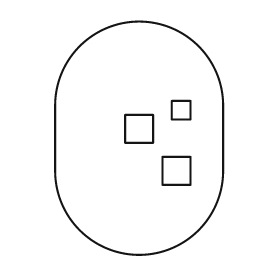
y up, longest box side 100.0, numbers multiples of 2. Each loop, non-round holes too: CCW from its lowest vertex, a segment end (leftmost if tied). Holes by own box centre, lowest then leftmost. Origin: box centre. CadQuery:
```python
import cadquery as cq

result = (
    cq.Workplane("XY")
    .moveTo(-36.0, -14.0)
    .threePointArc((0.0, -50.0), (36.0, -14.0))
    .lineTo(36.0, 14.0)
    .threePointArc((0.0, 50.0), (-36.0, 14.0))
    .close()
    .moveTo(10.0, -20.0)
    .lineTo(22.0, -20.0)
    .lineTo(22.0, -8.0)
    .lineTo(10.0, -8.0)
    .close()
    .moveTo(-6.0, -2.0)
    .lineTo(6.0, -2.0)
    .lineTo(6.0, 10.0)
    .lineTo(-6.0, 10.0)
    .close()
    .moveTo(14.0, 8.0)
    .lineTo(22.0, 8.0)
    .lineTo(22.0, 16.0)
    .lineTo(14.0, 16.0)
    .close()
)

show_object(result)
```